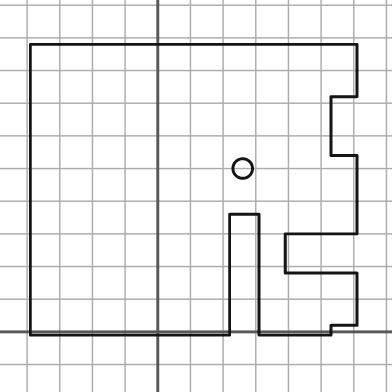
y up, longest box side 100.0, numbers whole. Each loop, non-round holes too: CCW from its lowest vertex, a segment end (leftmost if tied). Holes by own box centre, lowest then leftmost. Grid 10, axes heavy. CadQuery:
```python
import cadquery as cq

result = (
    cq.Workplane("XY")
    .moveTo(-39.0, -1.0)
    .lineTo(22.0, -1.0)
    .lineTo(22.0, 36.0)
    .lineTo(31.0, 36.0)
    .lineTo(31.0, -1.0)
    .lineTo(53.0, -1.0)
    .lineTo(53.0, 2.0)
    .lineTo(61.0, 2.0)
    .lineTo(61.0, 18.0)
    .lineTo(39.0, 18.0)
    .lineTo(39.0, 30.0)
    .lineTo(61.0, 30.0)
    .lineTo(61.0, 54.0)
    .lineTo(53.0, 54.0)
    .lineTo(53.0, 72.0)
    .lineTo(61.0, 72.0)
    .lineTo(61.0, 88.0)
    .lineTo(-39.0, 88.0)
    .close()
    .moveTo(26.0, 50.0)
    .circle(3.0)
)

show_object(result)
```